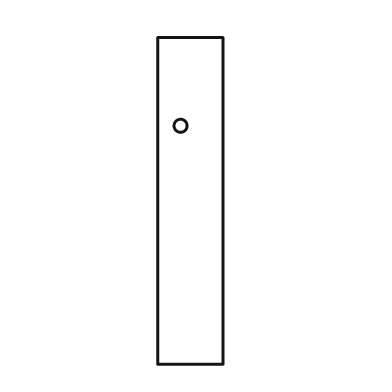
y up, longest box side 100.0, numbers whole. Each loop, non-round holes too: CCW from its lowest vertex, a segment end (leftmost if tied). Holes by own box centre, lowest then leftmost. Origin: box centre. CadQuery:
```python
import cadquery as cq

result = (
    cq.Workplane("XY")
    .moveTo(-10.0, -50.0)
    .lineTo(10.0, -50.0)
    .lineTo(10.0, 50.0)
    .lineTo(-10.0, 50.0)
    .close()
    .moveTo(-3.0, 23.0)
    .circle(2.0)
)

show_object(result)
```